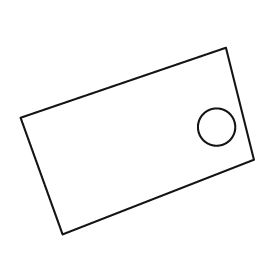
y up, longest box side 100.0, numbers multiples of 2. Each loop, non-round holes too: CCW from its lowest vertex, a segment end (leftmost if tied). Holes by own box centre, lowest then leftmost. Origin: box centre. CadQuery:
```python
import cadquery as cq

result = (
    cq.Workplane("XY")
    .moveTo(-32.0, -40.0)
    .lineTo(50.0, -8.0)
    .lineTo(38.0, 40.0)
    .lineTo(-50.0, 10.0)
    .close()
    .moveTo(34.0, 6.0)
    .circle(8.0)
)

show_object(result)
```